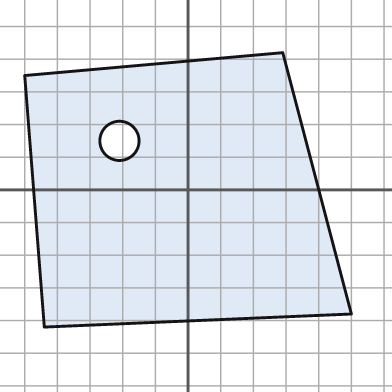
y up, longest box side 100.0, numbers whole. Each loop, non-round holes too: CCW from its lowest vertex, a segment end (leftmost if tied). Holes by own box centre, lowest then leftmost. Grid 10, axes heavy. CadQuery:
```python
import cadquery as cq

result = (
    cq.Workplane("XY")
    .moveTo(-44.0, -42.0)
    .lineTo(50.0, -38.0)
    .lineTo(29.0, 42.0)
    .lineTo(-50.0, 35.0)
    .close()
    .moveTo(-21.0, 15.0)
    .circle(6.0)
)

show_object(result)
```